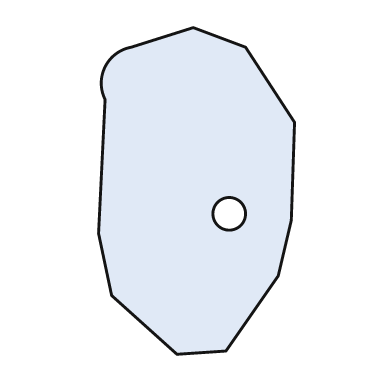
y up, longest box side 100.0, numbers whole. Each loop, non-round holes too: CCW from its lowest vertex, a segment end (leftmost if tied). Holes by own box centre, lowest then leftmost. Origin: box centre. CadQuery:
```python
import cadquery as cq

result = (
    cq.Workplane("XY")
    .moveTo(-6.0, -50.0)
    .lineTo(9.0, -49.0)
    .lineTo(25.0, -26.0)
    .lineTo(29.0, -9.0)
    .lineTo(30.0, 21.0)
    .lineTo(15.0, 44.0)
    .lineTo(-1.0, 50.0)
    .lineTo(-20.0, 44.0)
    .threePointArc((-28.0, 38.0), (-28.0, 28.0))
    .lineTo(-30.0, -13.0)
    .lineTo(-26.0, -32.0)
    .close()
    .moveTo(10.0, -7.0)
    .circle(5.0)
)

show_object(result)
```